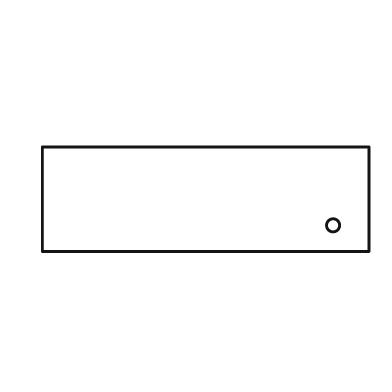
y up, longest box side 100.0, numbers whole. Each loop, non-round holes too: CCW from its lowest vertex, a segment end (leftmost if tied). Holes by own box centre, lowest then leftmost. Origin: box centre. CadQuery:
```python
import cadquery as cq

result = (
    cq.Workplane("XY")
    .moveTo(-50.0, -16.0)
    .lineTo(50.0, -16.0)
    .lineTo(50.0, 16.0)
    .lineTo(-50.0, 16.0)
    .close()
    .moveTo(39.0, -8.0)
    .circle(2.0)
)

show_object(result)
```